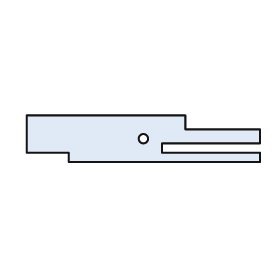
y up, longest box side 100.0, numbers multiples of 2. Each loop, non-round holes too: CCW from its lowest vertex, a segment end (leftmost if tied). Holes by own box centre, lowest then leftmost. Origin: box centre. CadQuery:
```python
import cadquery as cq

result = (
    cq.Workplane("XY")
    .moveTo(-32.0, -10.0)
    .lineTo(50.0, -10.0)
    .lineTo(50.0, -6.0)
    .lineTo(8.0, -6.0)
    .lineTo(8.0, -2.0)
    .lineTo(50.0, -2.0)
    .lineTo(50.0, 4.0)
    .lineTo(18.0, 4.0)
    .lineTo(18.0, 10.0)
    .lineTo(-50.0, 10.0)
    .lineTo(-50.0, -6.0)
    .lineTo(-32.0, -6.0)
    .close()
    .moveTo(0.0, 0.0)
    .circle(2.0)
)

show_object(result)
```